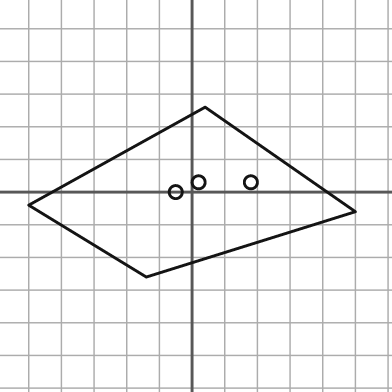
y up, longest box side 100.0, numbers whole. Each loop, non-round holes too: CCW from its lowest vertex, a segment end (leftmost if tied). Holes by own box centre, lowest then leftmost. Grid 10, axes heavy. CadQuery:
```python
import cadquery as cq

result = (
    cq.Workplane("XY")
    .moveTo(-14.0, -26.0)
    .lineTo(50.0, -6.0)
    .lineTo(4.0, 26.0)
    .lineTo(-50.0, -4.0)
    .close()
    .moveTo(-5.0, 0.0)
    .circle(2.0)
    .moveTo(2.0, 3.0)
    .circle(2.0)
    .moveTo(18.0, 3.0)
    .circle(2.0)
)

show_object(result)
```